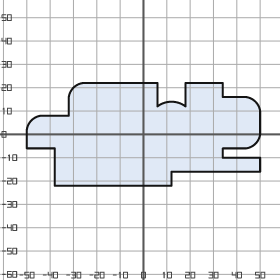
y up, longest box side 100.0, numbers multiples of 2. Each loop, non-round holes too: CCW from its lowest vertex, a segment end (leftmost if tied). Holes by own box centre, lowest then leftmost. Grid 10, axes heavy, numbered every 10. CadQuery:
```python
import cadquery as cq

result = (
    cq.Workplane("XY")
    .moveTo(-38.0, -22.0)
    .lineTo(12.0, -22.0)
    .lineTo(12.0, -16.0)
    .lineTo(50.0, -16.0)
    .lineTo(50.0, -10.0)
    .lineTo(34.0, -10.0)
    .lineTo(34.0, -6.0)
    .lineTo(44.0, -6.0)
    .threePointArc((48.0, -4.0), (50.0, 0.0))
    .lineTo(50.0, 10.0)
    .threePointArc((48.0, 14.0), (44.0, 16.0))
    .lineTo(34.0, 16.0)
    .lineTo(34.0, 22.0)
    .lineTo(18.0, 22.0)
    .lineTo(18.0, 12.0)
    .threePointArc((12.0, 14.0), (6.0, 12.0))
    .lineTo(6.0, 22.0)
    .lineTo(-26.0, 22.0)
    .threePointArc((-30.0, 20.0), (-32.0, 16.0))
    .lineTo(-32.0, 8.0)
    .lineTo(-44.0, 8.0)
    .threePointArc((-48.0, 6.0), (-50.0, 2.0))
    .lineTo(-50.0, -6.0)
    .lineTo(-38.0, -6.0)
    .close()
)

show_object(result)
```